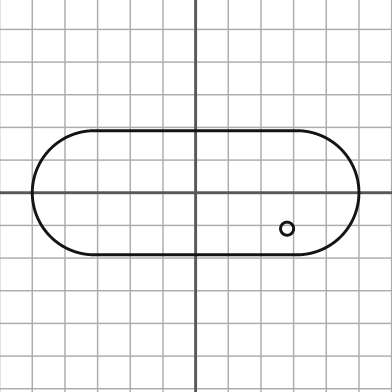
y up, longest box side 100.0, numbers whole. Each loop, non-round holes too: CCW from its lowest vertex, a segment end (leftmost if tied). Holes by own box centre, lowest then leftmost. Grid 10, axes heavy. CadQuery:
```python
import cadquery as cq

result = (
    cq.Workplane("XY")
    .moveTo(-31.0, -19.0)
    .lineTo(31.0, -19.0)
    .threePointArc((50.0, 0.0), (31.0, 19.0))
    .lineTo(-31.0, 19.0)
    .threePointArc((-50.0, 0.0), (-31.0, -19.0))
    .close()
    .moveTo(28.0, -11.0)
    .circle(2.0)
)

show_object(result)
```